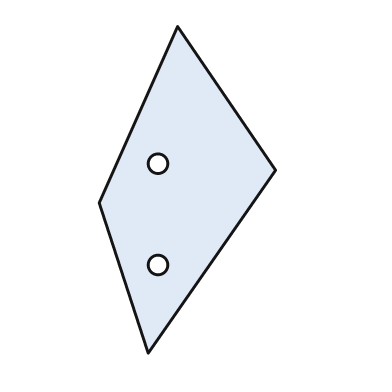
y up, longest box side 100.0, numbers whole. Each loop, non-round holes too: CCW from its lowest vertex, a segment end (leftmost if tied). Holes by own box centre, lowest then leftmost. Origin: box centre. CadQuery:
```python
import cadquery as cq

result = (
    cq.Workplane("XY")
    .moveTo(-12.0, -50.0)
    .lineTo(27.0, 6.0)
    .lineTo(-3.0, 50.0)
    .lineTo(-27.0, -4.0)
    .close()
    .moveTo(-9.0, -23.0)
    .circle(3.0)
    .moveTo(-9.0, 8.0)
    .circle(3.0)
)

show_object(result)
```